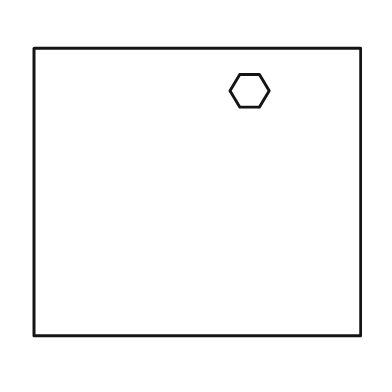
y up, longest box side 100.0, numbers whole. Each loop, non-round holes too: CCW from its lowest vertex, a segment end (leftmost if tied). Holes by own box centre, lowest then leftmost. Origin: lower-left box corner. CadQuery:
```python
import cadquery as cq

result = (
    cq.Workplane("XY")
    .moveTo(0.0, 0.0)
    .lineTo(100.0, 0.0)
    .lineTo(100.0, 88.0)
    .lineTo(0.0, 88.0)
    .close()
    .moveTo(63.0, 70.0)
    .lineTo(69.0, 70.0)
    .lineTo(72.0, 75.0)
    .lineTo(69.0, 80.0)
    .lineTo(63.0, 80.0)
    .lineTo(60.0, 75.0)
    .close()
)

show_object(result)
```